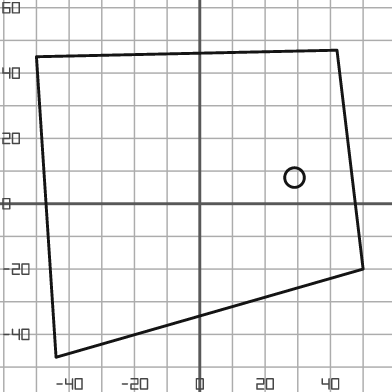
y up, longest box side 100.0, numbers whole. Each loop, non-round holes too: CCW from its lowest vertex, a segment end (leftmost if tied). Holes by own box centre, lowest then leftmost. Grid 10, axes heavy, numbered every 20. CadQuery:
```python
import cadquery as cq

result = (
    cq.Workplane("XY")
    .moveTo(-44.0, -47.0)
    .lineTo(50.0, -20.0)
    .lineTo(42.0, 47.0)
    .lineTo(-50.0, 45.0)
    .close()
    .moveTo(29.0, 8.0)
    .circle(3.0)
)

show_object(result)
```